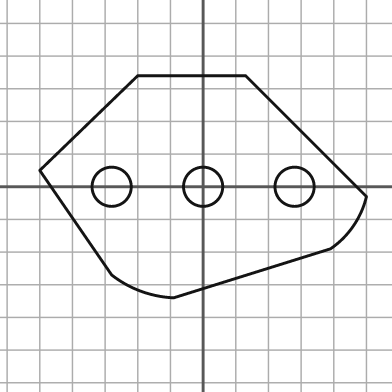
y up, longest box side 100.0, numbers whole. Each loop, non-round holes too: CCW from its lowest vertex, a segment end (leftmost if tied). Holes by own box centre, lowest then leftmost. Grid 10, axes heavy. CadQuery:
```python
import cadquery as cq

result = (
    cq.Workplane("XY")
    .moveTo(-9.0, -34.0)
    .lineTo(39.0, -19.0)
    .threePointArc((46.0, -12.0), (50.0, -3.0))
    .lineTo(13.0, 34.0)
    .lineTo(-20.0, 34.0)
    .lineTo(-50.0, 5.0)
    .lineTo(-28.0, -27.0)
    .threePointArc((-19.0, -32.0), (-9.0, -34.0))
    .close()
    .moveTo(-28.0, 0.0)
    .circle(6.0)
    .moveTo(0.0, 0.0)
    .circle(6.0)
    .moveTo(28.0, 0.0)
    .circle(6.0)
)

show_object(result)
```